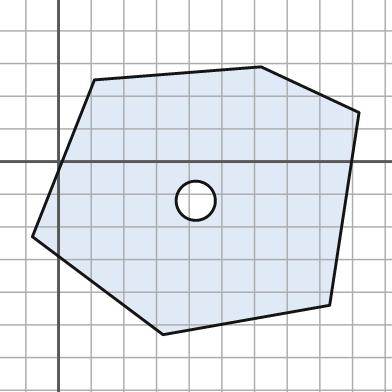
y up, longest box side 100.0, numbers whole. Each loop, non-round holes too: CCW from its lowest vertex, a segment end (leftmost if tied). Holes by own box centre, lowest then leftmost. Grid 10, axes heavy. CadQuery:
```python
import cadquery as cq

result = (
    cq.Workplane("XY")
    .moveTo(32.0, -53.0)
    .lineTo(83.0, -44.0)
    .lineTo(92.0, 15.0)
    .lineTo(62.0, 29.0)
    .lineTo(11.0, 25.0)
    .lineTo(-8.0, -23.0)
    .close()
    .moveTo(42.0, -12.0)
    .circle(6.0)
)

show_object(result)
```